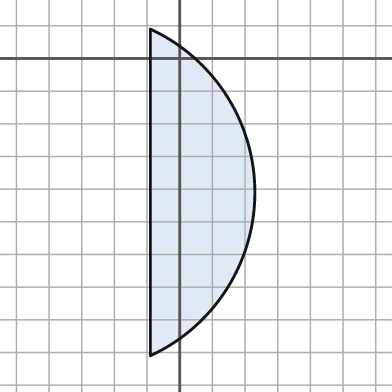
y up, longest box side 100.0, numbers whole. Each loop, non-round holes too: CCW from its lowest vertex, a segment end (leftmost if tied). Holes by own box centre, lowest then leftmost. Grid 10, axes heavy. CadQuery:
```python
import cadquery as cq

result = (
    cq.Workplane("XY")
    .moveTo(-9.0, -91.0)
    .threePointArc((23.0, -41.0), (-9.0, 9.0))
    .close()
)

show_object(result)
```